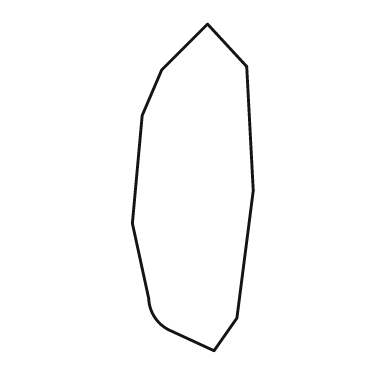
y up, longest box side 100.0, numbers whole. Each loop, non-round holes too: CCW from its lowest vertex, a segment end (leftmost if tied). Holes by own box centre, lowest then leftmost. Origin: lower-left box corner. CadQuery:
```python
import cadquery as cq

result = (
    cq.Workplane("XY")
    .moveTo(25.0, 0.0)
    .lineTo(32.0, 10.0)
    .lineTo(37.0, 49.0)
    .lineTo(35.0, 87.0)
    .lineTo(23.0, 100.0)
    .lineTo(9.0, 86.0)
    .lineTo(3.0, 72.0)
    .lineTo(0.0, 39.0)
    .lineTo(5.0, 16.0)
    .threePointArc((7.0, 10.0), (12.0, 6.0))
    .close()
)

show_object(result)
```